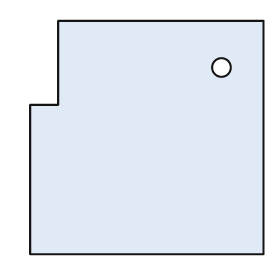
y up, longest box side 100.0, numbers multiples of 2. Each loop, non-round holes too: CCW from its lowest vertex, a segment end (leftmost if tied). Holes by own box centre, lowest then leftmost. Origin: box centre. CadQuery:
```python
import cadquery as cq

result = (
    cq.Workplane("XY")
    .moveTo(-50.0, -50.0)
    .lineTo(50.0, -50.0)
    .lineTo(50.0, 50.0)
    .lineTo(-38.0, 50.0)
    .lineTo(-38.0, 14.0)
    .lineTo(-50.0, 14.0)
    .close()
    .moveTo(32.0, 30.0)
    .circle(4.0)
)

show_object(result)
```